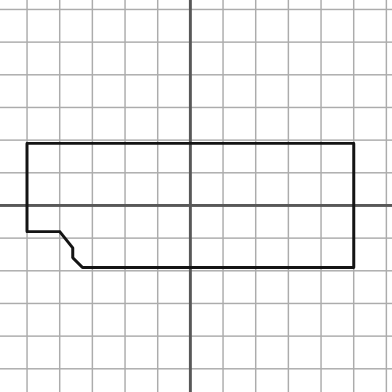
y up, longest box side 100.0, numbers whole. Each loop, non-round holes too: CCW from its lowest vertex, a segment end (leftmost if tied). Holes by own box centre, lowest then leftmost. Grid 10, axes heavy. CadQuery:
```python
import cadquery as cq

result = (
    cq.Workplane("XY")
    .moveTo(-33.0, -19.0)
    .lineTo(50.0, -19.0)
    .lineTo(50.0, 19.0)
    .lineTo(-50.0, 19.0)
    .lineTo(-50.0, -8.0)
    .lineTo(-40.0, -8.0)
    .lineTo(-36.0, -13.0)
    .lineTo(-36.0, -16.0)
    .close()
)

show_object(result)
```